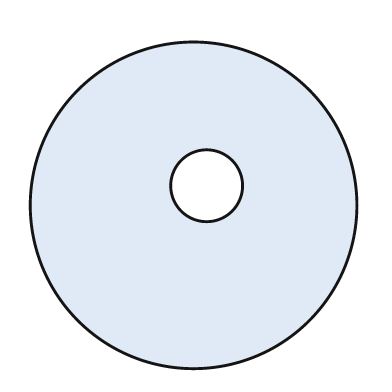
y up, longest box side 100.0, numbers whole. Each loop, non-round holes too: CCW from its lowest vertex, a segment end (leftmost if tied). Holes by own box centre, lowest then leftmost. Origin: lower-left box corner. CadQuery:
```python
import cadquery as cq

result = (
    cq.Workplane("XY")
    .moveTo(50.0, 50.0)
    .circle(50.0)
    .moveTo(54.0, 56.0)
    .circle(11.0)
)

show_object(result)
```